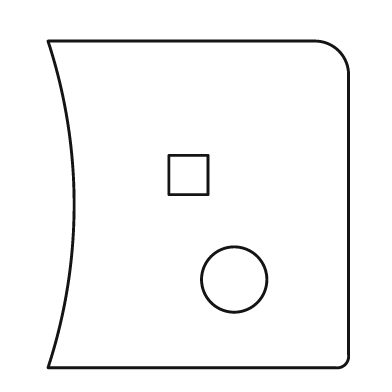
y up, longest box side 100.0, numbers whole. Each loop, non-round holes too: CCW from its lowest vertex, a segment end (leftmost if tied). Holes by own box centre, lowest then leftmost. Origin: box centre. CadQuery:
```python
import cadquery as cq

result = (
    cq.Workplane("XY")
    .moveTo(-46.0, -50.0)
    .lineTo(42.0, -50.0)
    .threePointArc((45.0, -49.0), (46.0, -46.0))
    .lineTo(46.0, 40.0)
    .threePointArc((43.0, 47.0), (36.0, 50.0))
    .lineTo(-46.0, 50.0)
    .threePointArc((-38.0, 0.0), (-46.0, -50.0))
    .close()
    .moveTo(11.0, -23.0)
    .circle(10.0)
    .moveTo(-9.0, 3.0)
    .lineTo(3.0, 3.0)
    .lineTo(3.0, 15.0)
    .lineTo(-9.0, 15.0)
    .close()
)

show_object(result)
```